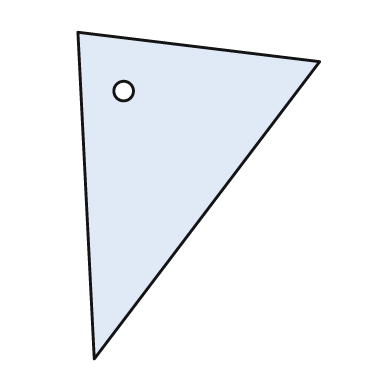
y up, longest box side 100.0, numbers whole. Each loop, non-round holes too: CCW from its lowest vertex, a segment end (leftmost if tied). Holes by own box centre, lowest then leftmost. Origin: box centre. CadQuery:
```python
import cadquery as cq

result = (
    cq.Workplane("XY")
    .moveTo(-32.0, -50.0)
    .lineTo(37.0, 41.0)
    .lineTo(-37.0, 50.0)
    .close()
    .moveTo(-23.0, 32.0)
    .circle(3.0)
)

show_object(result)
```